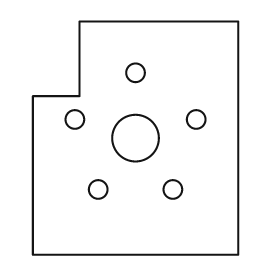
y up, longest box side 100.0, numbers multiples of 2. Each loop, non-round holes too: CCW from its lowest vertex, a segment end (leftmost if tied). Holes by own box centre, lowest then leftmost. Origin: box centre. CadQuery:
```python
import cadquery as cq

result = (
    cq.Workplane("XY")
    .moveTo(-44.0, -50.0)
    .lineTo(44.0, -50.0)
    .lineTo(44.0, 50.0)
    .lineTo(-24.0, 50.0)
    .lineTo(-24.0, 18.0)
    .lineTo(-44.0, 18.0)
    .close()
    .moveTo(-16.0, -22.0)
    .circle(4.0)
    .moveTo(16.0, -22.0)
    .circle(4.0)
    .moveTo(0.0, 0.0)
    .circle(10.0)
    .moveTo(-26.0, 8.0)
    .circle(4.0)
    .moveTo(26.0, 8.0)
    .circle(4.0)
    .moveTo(0.0, 28.0)
    .circle(4.0)
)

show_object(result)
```